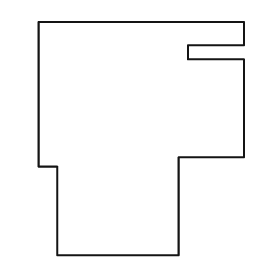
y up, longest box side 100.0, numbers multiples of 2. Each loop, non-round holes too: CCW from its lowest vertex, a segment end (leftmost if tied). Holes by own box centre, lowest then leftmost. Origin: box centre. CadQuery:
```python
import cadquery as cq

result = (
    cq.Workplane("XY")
    .moveTo(-36.0, -50.0)
    .lineTo(16.0, -50.0)
    .lineTo(16.0, -8.0)
    .lineTo(44.0, -8.0)
    .lineTo(44.0, 34.0)
    .lineTo(20.0, 34.0)
    .lineTo(20.0, 40.0)
    .lineTo(44.0, 40.0)
    .lineTo(44.0, 50.0)
    .lineTo(-44.0, 50.0)
    .lineTo(-44.0, -12.0)
    .lineTo(-36.0, -12.0)
    .close()
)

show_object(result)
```